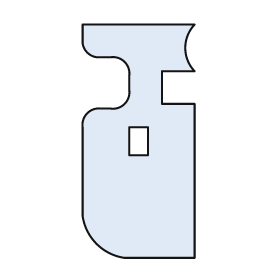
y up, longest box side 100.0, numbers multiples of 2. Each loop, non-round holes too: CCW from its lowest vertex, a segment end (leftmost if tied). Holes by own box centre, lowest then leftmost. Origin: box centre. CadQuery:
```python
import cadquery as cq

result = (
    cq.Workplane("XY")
    .moveTo(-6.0, -50.0)
    .lineTo(24.0, -50.0)
    .lineTo(24.0, 16.0)
    .lineTo(10.0, 16.0)
    .lineTo(10.0, 30.0)
    .lineTo(24.0, 30.0)
    .threePointArc((20.0, 40.0), (24.0, 50.0))
    .lineTo(-24.0, 50.0)
    .lineTo(-24.0, 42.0)
    .threePointArc((-22.0, 38.0), (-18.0, 36.0))
    .lineTo(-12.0, 36.0)
    .threePointArc((-6.0, 34.0), (-4.0, 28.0))
    .lineTo(-4.0, 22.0)
    .threePointArc((-6.0, 16.0), (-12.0, 14.0))
    .lineTo(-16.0, 14.0)
    .threePointArc((-22.0, 12.0), (-24.0, 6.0))
    .lineTo(-24.0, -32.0)
    .threePointArc((-18.0, -44.0), (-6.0, -50.0))
    .close()
    .moveTo(-4.0, -6.0)
    .lineTo(4.0, -6.0)
    .lineTo(4.0, 6.0)
    .lineTo(-4.0, 6.0)
    .close()
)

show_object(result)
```